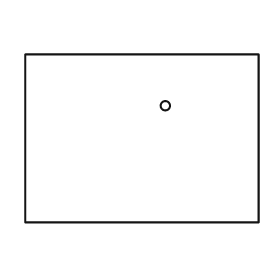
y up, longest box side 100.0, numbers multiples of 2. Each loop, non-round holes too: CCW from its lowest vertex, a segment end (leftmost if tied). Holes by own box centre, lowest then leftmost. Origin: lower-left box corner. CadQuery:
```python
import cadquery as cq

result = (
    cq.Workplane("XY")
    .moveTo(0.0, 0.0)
    .lineTo(100.0, 0.0)
    .lineTo(100.0, 72.0)
    .lineTo(0.0, 72.0)
    .close()
    .moveTo(60.0, 50.0)
    .circle(2.0)
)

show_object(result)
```